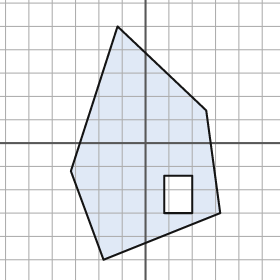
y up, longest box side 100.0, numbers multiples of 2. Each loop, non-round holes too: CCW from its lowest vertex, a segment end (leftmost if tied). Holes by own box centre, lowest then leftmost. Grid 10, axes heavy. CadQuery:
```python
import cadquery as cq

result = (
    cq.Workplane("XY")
    .moveTo(-18.0, -50.0)
    .lineTo(32.0, -30.0)
    .lineTo(26.0, 14.0)
    .lineTo(-12.0, 50.0)
    .lineTo(-32.0, -12.0)
    .close()
    .moveTo(8.0, -30.0)
    .lineTo(20.0, -30.0)
    .lineTo(20.0, -14.0)
    .lineTo(8.0, -14.0)
    .close()
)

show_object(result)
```